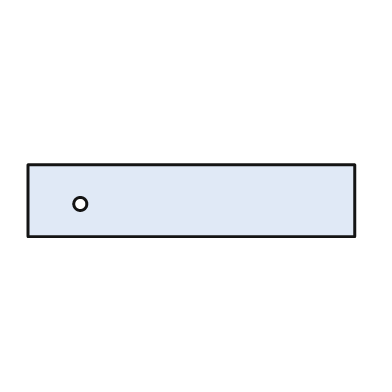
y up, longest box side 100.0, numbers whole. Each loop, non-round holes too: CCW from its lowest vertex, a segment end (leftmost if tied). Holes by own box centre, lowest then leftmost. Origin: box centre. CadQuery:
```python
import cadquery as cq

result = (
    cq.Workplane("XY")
    .moveTo(-50.0, -11.0)
    .lineTo(50.0, -11.0)
    .lineTo(50.0, 11.0)
    .lineTo(-50.0, 11.0)
    .close()
    .moveTo(-34.0, -1.0)
    .circle(2.0)
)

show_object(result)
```